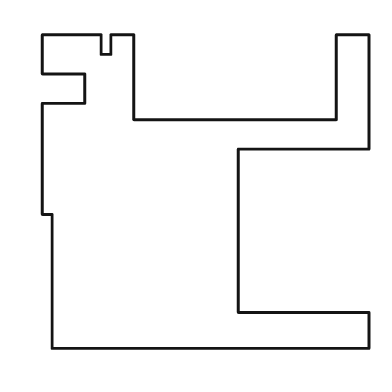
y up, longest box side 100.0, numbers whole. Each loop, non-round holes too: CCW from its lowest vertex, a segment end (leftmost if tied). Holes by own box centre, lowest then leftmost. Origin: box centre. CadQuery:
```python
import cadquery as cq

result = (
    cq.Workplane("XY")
    .moveTo(-47.0, -48.0)
    .lineTo(50.0, -48.0)
    .lineTo(50.0, -37.0)
    .lineTo(10.0, -37.0)
    .lineTo(10.0, 13.0)
    .lineTo(50.0, 13.0)
    .lineTo(50.0, 48.0)
    .lineTo(40.0, 48.0)
    .lineTo(40.0, 22.0)
    .lineTo(-22.0, 22.0)
    .lineTo(-22.0, 48.0)
    .lineTo(-29.0, 48.0)
    .lineTo(-29.0, 42.0)
    .lineTo(-32.0, 42.0)
    .lineTo(-32.0, 48.0)
    .lineTo(-50.0, 48.0)
    .lineTo(-50.0, 36.0)
    .lineTo(-37.0, 36.0)
    .lineTo(-37.0, 27.0)
    .lineTo(-50.0, 27.0)
    .lineTo(-50.0, -7.0)
    .lineTo(-47.0, -7.0)
    .close()
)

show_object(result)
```